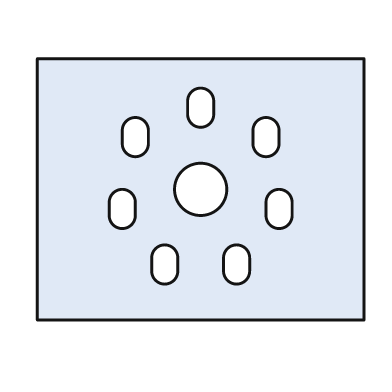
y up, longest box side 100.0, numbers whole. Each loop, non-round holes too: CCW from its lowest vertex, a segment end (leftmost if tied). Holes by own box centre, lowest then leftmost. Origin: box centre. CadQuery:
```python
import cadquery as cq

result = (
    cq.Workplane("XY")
    .moveTo(-50.0, -40.0)
    .lineTo(50.0, -40.0)
    .lineTo(50.0, 40.0)
    .lineTo(-50.0, 40.0)
    .close()
    .moveTo(-15.0, -25.0)
    .threePointArc((-11.0, -29.0), (-7.0, -25.0))
    .lineTo(-7.0, -21.0)
    .threePointArc((-11.0, -17.0), (-15.0, -21.0))
    .close()
    .moveTo(7.0, -25.0)
    .threePointArc((11.0, -29.0), (15.0, -25.0))
    .lineTo(15.0, -21.0)
    .threePointArc((11.0, -17.0), (7.0, -21.0))
    .close()
    .moveTo(-28.0, -8.0)
    .threePointArc((-24.0, -12.0), (-20.0, -8.0))
    .lineTo(-20.0, -4.0)
    .threePointArc((-24.0, 0.0), (-28.0, -4.0))
    .close()
    .moveTo(20.0, -8.0)
    .threePointArc((24.0, -12.0), (28.0, -8.0))
    .lineTo(28.0, -4.0)
    .threePointArc((24.0, 0.0), (20.0, -4.0))
    .close()
    .moveTo(0.0, 0.0)
    .circle(8.0)
    .moveTo(-24.0, 14.0)
    .threePointArc((-20.0, 10.0), (-16.0, 14.0))
    .lineTo(-16.0, 18.0)
    .threePointArc((-20.0, 22.0), (-24.0, 18.0))
    .close()
    .moveTo(16.0, 14.0)
    .threePointArc((20.0, 10.0), (24.0, 14.0))
    .lineTo(24.0, 18.0)
    .threePointArc((20.0, 22.0), (16.0, 18.0))
    .close()
    .moveTo(-4.0, 23.0)
    .threePointArc((0.0, 19.0), (4.0, 23.0))
    .lineTo(4.0, 27.0)
    .threePointArc((0.0, 31.0), (-4.0, 27.0))
    .close()
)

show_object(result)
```